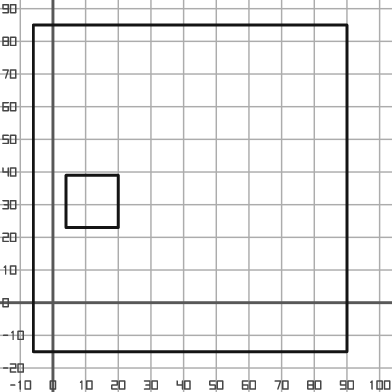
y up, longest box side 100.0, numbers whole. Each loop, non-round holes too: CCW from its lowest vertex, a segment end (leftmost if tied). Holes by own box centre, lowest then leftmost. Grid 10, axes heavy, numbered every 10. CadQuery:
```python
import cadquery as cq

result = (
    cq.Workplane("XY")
    .moveTo(-6.0, -15.0)
    .lineTo(90.0, -15.0)
    .lineTo(90.0, 85.0)
    .lineTo(-6.0, 85.0)
    .close()
    .moveTo(4.0, 23.0)
    .lineTo(20.0, 23.0)
    .lineTo(20.0, 39.0)
    .lineTo(4.0, 39.0)
    .close()
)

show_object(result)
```